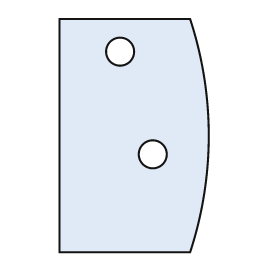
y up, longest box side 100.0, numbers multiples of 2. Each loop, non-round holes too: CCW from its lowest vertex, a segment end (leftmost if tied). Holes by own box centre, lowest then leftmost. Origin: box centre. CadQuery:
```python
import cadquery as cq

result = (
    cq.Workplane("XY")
    .moveTo(-32.0, -50.0)
    .lineTo(24.0, -50.0)
    .threePointArc((32.0, 0.0), (24.0, 50.0))
    .lineTo(-32.0, 50.0)
    .close()
    .moveTo(8.0, -8.0)
    .circle(6.0)
    .moveTo(-6.0, 36.0)
    .circle(6.0)
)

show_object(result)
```